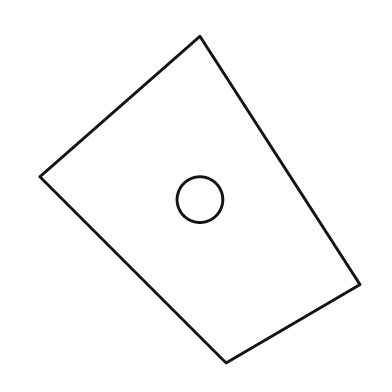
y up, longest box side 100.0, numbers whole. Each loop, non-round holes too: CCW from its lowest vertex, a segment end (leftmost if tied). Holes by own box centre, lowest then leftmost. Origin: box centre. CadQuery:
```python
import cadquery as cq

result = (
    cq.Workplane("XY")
    .moveTo(8.0, -50.0)
    .lineTo(49.0, -26.0)
    .lineTo(0.0, 50.0)
    .lineTo(-49.0, 7.0)
    .close()
    .moveTo(0.0, 0.0)
    .circle(7.0)
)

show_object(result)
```